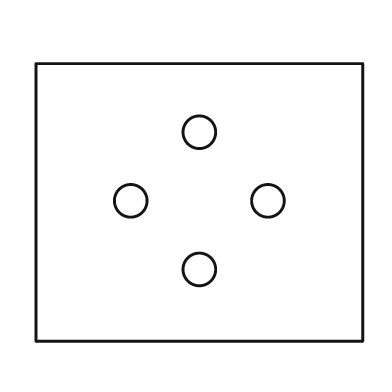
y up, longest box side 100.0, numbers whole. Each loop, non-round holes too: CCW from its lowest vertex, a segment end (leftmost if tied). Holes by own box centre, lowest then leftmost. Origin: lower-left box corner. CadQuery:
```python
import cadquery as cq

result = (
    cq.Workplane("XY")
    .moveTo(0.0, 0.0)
    .lineTo(100.0, 0.0)
    .lineTo(100.0, 85.0)
    .lineTo(0.0, 85.0)
    .close()
    .moveTo(50.0, 22.0)
    .circle(5.0)
    .moveTo(29.0, 43.0)
    .circle(5.0)
    .moveTo(71.0, 43.0)
    .circle(5.0)
    .moveTo(50.0, 64.0)
    .circle(5.0)
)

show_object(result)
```